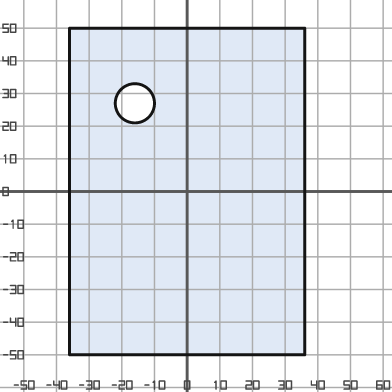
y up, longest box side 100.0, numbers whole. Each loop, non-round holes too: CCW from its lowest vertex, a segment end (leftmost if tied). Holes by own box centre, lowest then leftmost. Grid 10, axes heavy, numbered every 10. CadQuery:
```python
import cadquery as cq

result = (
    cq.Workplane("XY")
    .moveTo(-36.0, -50.0)
    .lineTo(36.0, -50.0)
    .lineTo(36.0, 50.0)
    .lineTo(-36.0, 50.0)
    .close()
    .moveTo(-16.0, 27.0)
    .circle(6.0)
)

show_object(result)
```